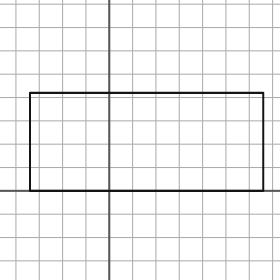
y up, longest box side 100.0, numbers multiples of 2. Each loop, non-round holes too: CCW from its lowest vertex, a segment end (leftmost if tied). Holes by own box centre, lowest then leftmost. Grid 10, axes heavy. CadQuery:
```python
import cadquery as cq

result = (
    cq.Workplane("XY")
    .moveTo(-34.0, 0.0)
    .lineTo(66.0, 0.0)
    .lineTo(66.0, 42.0)
    .lineTo(-34.0, 42.0)
    .close()
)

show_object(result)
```